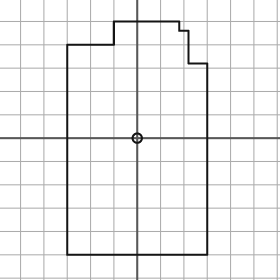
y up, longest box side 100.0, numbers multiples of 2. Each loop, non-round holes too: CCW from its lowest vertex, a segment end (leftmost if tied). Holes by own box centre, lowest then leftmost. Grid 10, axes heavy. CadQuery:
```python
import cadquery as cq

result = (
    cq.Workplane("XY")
    .moveTo(-30.0, -50.0)
    .lineTo(30.0, -50.0)
    .lineTo(30.0, 32.0)
    .lineTo(22.0, 32.0)
    .lineTo(22.0, 46.0)
    .lineTo(18.0, 46.0)
    .lineTo(18.0, 50.0)
    .lineTo(-10.0, 50.0)
    .lineTo(-10.0, 40.0)
    .lineTo(-30.0, 40.0)
    .close()
    .moveTo(0.0, 0.0)
    .circle(2.0)
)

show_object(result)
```